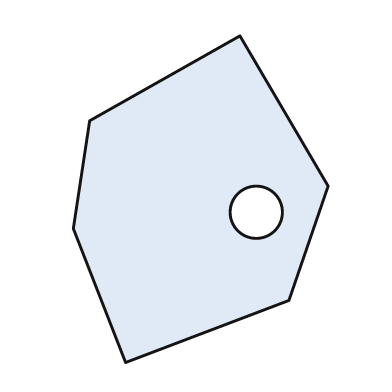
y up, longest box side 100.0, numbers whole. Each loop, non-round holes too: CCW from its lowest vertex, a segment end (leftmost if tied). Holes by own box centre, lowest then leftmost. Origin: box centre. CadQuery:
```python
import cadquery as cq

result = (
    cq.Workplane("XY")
    .moveTo(-23.0, -50.0)
    .lineTo(27.0, -31.0)
    .lineTo(39.0, 4.0)
    .lineTo(12.0, 50.0)
    .lineTo(-34.0, 24.0)
    .lineTo(-39.0, -9.0)
    .close()
    .moveTo(17.0, -4.0)
    .circle(8.0)
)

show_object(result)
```